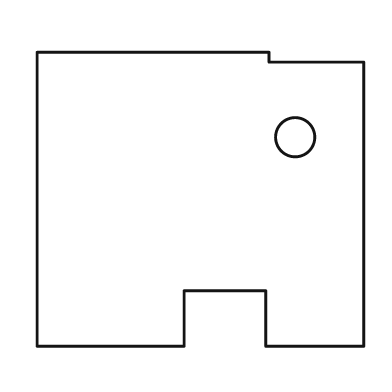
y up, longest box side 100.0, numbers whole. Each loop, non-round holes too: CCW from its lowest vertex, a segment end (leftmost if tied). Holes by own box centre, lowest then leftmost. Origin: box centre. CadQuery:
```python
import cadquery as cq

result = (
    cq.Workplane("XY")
    .moveTo(-50.0, -45.0)
    .lineTo(-5.0, -45.0)
    .lineTo(-5.0, -28.0)
    .lineTo(20.0, -28.0)
    .lineTo(20.0, -45.0)
    .lineTo(50.0, -45.0)
    .lineTo(50.0, 42.0)
    .lineTo(21.0, 42.0)
    .lineTo(21.0, 45.0)
    .lineTo(-50.0, 45.0)
    .close()
    .moveTo(29.0, 19.0)
    .circle(6.0)
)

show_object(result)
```